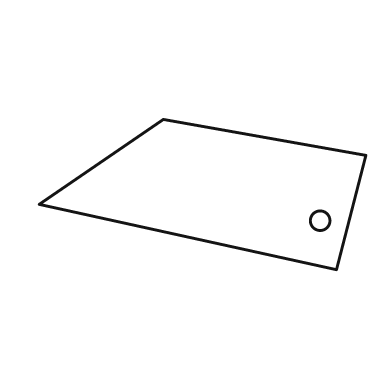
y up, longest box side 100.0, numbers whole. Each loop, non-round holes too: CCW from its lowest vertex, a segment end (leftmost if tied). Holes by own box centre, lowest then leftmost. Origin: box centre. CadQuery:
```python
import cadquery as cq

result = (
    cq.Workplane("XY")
    .moveTo(41.0, -23.0)
    .lineTo(50.0, 12.0)
    .lineTo(-12.0, 23.0)
    .lineTo(-50.0, -3.0)
    .close()
    .moveTo(36.0, -8.0)
    .circle(3.0)
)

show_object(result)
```